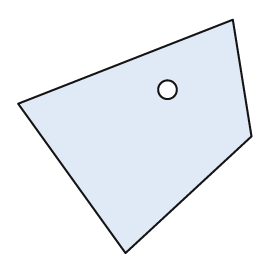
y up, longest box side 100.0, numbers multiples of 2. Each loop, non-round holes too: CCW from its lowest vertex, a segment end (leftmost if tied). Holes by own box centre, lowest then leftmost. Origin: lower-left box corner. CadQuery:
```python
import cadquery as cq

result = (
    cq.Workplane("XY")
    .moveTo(46.0, 0.0)
    .lineTo(100.0, 50.0)
    .lineTo(92.0, 100.0)
    .lineTo(0.0, 64.0)
    .close()
    .moveTo(64.0, 70.0)
    .circle(4.0)
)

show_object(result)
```